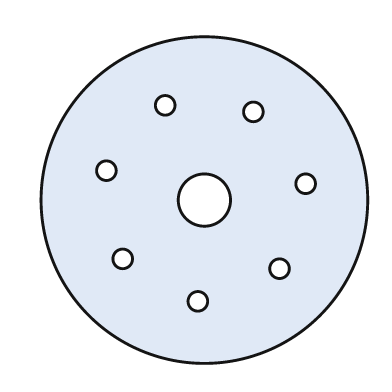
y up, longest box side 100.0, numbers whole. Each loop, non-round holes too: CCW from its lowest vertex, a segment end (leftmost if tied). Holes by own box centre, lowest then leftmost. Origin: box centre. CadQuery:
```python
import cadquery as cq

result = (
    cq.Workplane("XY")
    .moveTo(0.0, 0.0)
    .circle(50.0)
    .moveTo(-2.0, -31.0)
    .circle(3.0)
    .moveTo(23.0, -21.0)
    .circle(3.0)
    .moveTo(-25.0, -18.0)
    .circle(3.0)
    .moveTo(0.0, 0.0)
    .circle(8.0)
    .moveTo(31.0, 5.0)
    .circle(3.0)
    .moveTo(-30.0, 9.0)
    .circle(3.0)
    .moveTo(15.0, 27.0)
    .circle(3.0)
    .moveTo(-12.0, 29.0)
    .circle(3.0)
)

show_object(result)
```